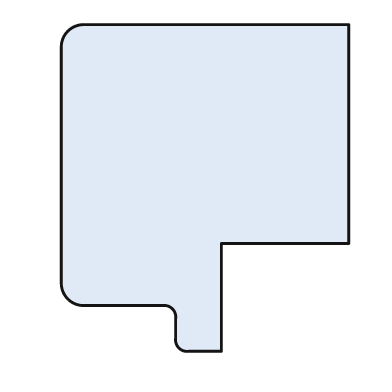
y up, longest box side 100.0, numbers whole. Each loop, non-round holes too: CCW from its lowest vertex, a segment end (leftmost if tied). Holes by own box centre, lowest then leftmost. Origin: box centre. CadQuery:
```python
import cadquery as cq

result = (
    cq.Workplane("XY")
    .moveTo(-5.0, -50.0)
    .lineTo(5.0, -50.0)
    .lineTo(5.0, -17.0)
    .lineTo(44.0, -17.0)
    .lineTo(44.0, 50.0)
    .lineTo(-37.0, 50.0)
    .threePointArc((-42.0, 48.0), (-44.0, 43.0))
    .lineTo(-44.0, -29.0)
    .threePointArc((-42.0, -34.0), (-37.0, -36.0))
    .lineTo(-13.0, -36.0)
    .threePointArc((-10.0, -37.0), (-9.0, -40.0))
    .lineTo(-9.0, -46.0)
    .threePointArc((-8.0, -49.0), (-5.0, -50.0))
    .close()
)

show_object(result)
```